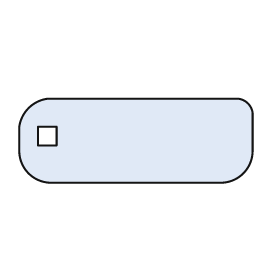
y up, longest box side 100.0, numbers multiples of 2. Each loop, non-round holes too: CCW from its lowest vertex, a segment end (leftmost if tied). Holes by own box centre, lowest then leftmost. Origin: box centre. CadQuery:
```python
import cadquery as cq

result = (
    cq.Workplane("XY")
    .moveTo(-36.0, -18.0)
    .lineTo(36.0, -18.0)
    .threePointArc((46.0, -14.0), (50.0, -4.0))
    .lineTo(50.0, 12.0)
    .threePointArc((48.0, 16.0), (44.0, 18.0))
    .lineTo(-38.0, 18.0)
    .threePointArc((-46.0, 14.0), (-50.0, 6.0))
    .lineTo(-50.0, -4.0)
    .threePointArc((-46.0, -14.0), (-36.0, -18.0))
    .close()
    .moveTo(-42.0, -2.0)
    .lineTo(-34.0, -2.0)
    .lineTo(-34.0, 6.0)
    .lineTo(-42.0, 6.0)
    .close()
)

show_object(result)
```